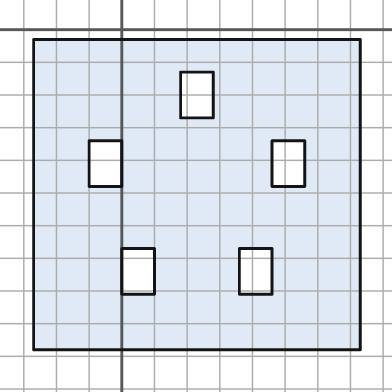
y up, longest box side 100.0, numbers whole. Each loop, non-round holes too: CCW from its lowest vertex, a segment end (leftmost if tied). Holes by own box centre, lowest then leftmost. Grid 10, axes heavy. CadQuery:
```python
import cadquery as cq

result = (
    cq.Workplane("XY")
    .moveTo(-27.0, -98.0)
    .lineTo(73.0, -98.0)
    .lineTo(73.0, -3.0)
    .lineTo(-27.0, -3.0)
    .close()
    .moveTo(0.0, -81.0)
    .lineTo(10.0, -81.0)
    .lineTo(10.0, -67.0)
    .lineTo(0.0, -67.0)
    .close()
    .moveTo(36.0, -81.0)
    .lineTo(46.0, -81.0)
    .lineTo(46.0, -67.0)
    .lineTo(36.0, -67.0)
    .close()
    .moveTo(-10.0, -48.0)
    .lineTo(0.0, -48.0)
    .lineTo(0.0, -34.0)
    .lineTo(-10.0, -34.0)
    .close()
    .moveTo(46.0, -48.0)
    .lineTo(56.0, -48.0)
    .lineTo(56.0, -34.0)
    .lineTo(46.0, -34.0)
    .close()
    .moveTo(18.0, -27.0)
    .lineTo(28.0, -27.0)
    .lineTo(28.0, -13.0)
    .lineTo(18.0, -13.0)
    .close()
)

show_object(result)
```